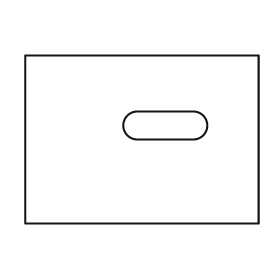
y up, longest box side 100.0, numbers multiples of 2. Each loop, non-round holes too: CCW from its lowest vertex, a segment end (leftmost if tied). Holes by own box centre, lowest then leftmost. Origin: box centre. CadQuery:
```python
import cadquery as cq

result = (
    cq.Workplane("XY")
    .moveTo(-50.0, -36.0)
    .lineTo(50.0, -36.0)
    .lineTo(50.0, 36.0)
    .lineTo(-50.0, 36.0)
    .close()
    .moveTo(-2.0, 0.0)
    .lineTo(22.0, 0.0)
    .threePointArc((28.0, 6.0), (22.0, 12.0))
    .lineTo(-2.0, 12.0)
    .threePointArc((-8.0, 6.0), (-2.0, 0.0))
    .close()
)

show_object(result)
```